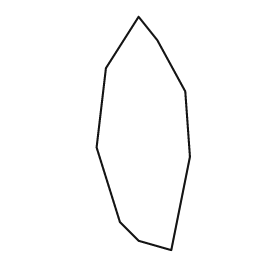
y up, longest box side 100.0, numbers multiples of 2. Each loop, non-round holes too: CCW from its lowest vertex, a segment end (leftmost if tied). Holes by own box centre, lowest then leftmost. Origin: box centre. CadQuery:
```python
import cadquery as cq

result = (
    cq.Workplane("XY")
    .moveTo(12.0, -50.0)
    .lineTo(20.0, -10.0)
    .lineTo(18.0, 18.0)
    .lineTo(6.0, 40.0)
    .lineTo(-2.0, 50.0)
    .lineTo(-16.0, 28.0)
    .lineTo(-20.0, -6.0)
    .lineTo(-10.0, -38.0)
    .lineTo(-2.0, -46.0)
    .close()
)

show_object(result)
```